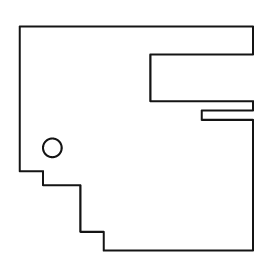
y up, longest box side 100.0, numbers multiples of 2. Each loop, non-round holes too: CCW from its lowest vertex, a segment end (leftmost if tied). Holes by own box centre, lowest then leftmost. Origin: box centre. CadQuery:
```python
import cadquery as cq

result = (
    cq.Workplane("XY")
    .moveTo(-14.0, -48.0)
    .lineTo(50.0, -48.0)
    .lineTo(50.0, 8.0)
    .lineTo(28.0, 8.0)
    .lineTo(28.0, 12.0)
    .lineTo(50.0, 12.0)
    .lineTo(50.0, 16.0)
    .lineTo(6.0, 16.0)
    .lineTo(6.0, 36.0)
    .lineTo(50.0, 36.0)
    .lineTo(50.0, 48.0)
    .lineTo(-50.0, 48.0)
    .lineTo(-50.0, -14.0)
    .lineTo(-40.0, -14.0)
    .lineTo(-40.0, -20.0)
    .lineTo(-24.0, -20.0)
    .lineTo(-24.0, -40.0)
    .lineTo(-14.0, -40.0)
    .close()
    .moveTo(-36.0, -4.0)
    .circle(4.0)
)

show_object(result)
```